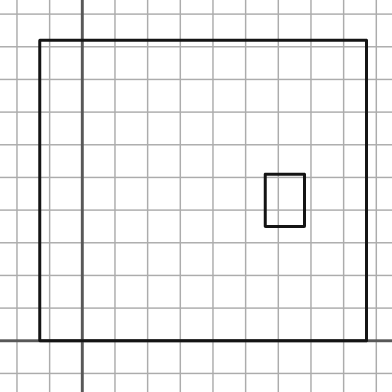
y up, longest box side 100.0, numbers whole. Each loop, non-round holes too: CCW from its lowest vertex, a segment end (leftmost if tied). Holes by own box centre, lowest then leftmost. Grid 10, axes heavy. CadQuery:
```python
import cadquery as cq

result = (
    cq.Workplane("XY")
    .moveTo(-13.0, 0.0)
    .lineTo(87.0, 0.0)
    .lineTo(87.0, 92.0)
    .lineTo(-13.0, 92.0)
    .close()
    .moveTo(56.0, 35.0)
    .lineTo(68.0, 35.0)
    .lineTo(68.0, 51.0)
    .lineTo(56.0, 51.0)
    .close()
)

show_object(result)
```